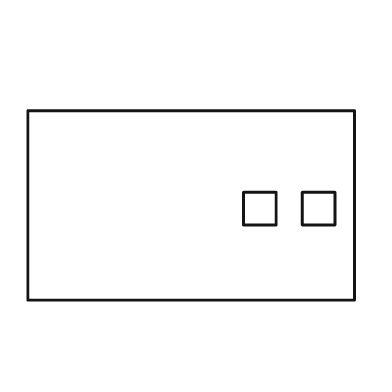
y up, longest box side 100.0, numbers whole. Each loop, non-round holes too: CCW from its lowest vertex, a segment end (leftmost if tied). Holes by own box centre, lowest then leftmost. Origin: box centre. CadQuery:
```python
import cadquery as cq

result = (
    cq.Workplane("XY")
    .moveTo(-50.0, -29.0)
    .lineTo(50.0, -29.0)
    .lineTo(50.0, 29.0)
    .lineTo(-50.0, 29.0)
    .close()
    .moveTo(16.0, -6.0)
    .lineTo(26.0, -6.0)
    .lineTo(26.0, 4.0)
    .lineTo(16.0, 4.0)
    .close()
    .moveTo(34.0, -6.0)
    .lineTo(44.0, -6.0)
    .lineTo(44.0, 4.0)
    .lineTo(34.0, 4.0)
    .close()
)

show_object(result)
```